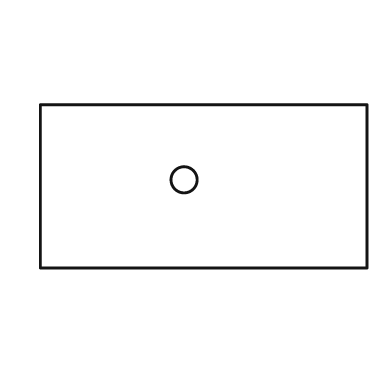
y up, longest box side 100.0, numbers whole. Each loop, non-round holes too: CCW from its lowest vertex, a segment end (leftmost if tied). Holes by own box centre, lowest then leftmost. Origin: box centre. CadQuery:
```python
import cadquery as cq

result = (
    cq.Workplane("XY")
    .moveTo(-50.0, -25.0)
    .lineTo(50.0, -25.0)
    .lineTo(50.0, 25.0)
    .lineTo(-50.0, 25.0)
    .close()
    .moveTo(-6.0, 2.0)
    .circle(4.0)
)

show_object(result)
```